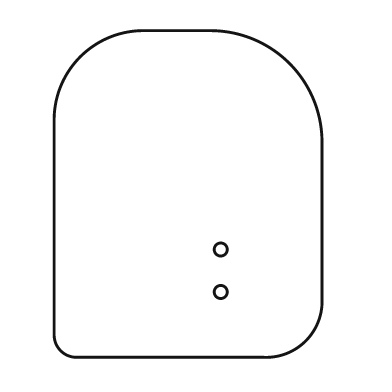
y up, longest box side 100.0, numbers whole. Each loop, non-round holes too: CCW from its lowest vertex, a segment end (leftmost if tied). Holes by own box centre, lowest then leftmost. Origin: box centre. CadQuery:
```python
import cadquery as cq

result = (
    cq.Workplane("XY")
    .moveTo(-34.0, -50.0)
    .lineTo(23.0, -50.0)
    .threePointArc((36.0, -45.0), (41.0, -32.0))
    .lineTo(41.0, 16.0)
    .threePointArc((31.0, 40.0), (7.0, 50.0))
    .lineTo(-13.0, 50.0)
    .threePointArc((-33.0, 42.0), (-41.0, 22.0))
    .lineTo(-41.0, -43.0)
    .threePointArc((-39.0, -48.0), (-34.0, -50.0))
    .close()
    .moveTo(10.0, -30.0)
    .circle(2.0)
    .moveTo(10.0, -17.0)
    .circle(2.0)
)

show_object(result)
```